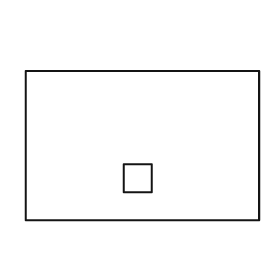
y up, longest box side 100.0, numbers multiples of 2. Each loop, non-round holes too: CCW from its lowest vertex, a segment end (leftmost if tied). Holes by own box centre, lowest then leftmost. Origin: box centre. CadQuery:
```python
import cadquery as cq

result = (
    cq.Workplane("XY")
    .moveTo(-50.0, -32.0)
    .lineTo(50.0, -32.0)
    .lineTo(50.0, 32.0)
    .lineTo(-50.0, 32.0)
    .close()
    .moveTo(-8.0, -20.0)
    .lineTo(4.0, -20.0)
    .lineTo(4.0, -8.0)
    .lineTo(-8.0, -8.0)
    .close()
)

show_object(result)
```